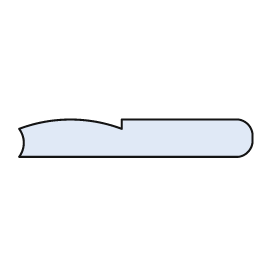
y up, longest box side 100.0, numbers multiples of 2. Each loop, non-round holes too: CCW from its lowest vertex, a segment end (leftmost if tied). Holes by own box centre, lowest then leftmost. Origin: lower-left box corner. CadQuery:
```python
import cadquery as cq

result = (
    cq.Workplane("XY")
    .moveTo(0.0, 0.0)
    .lineTo(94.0, 0.0)
    .threePointArc((98.0, 2.0), (100.0, 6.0))
    .lineTo(100.0, 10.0)
    .threePointArc((98.0, 14.0), (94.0, 16.0))
    .lineTo(44.0, 16.0)
    .lineTo(44.0, 12.0)
    .threePointArc((22.0, 16.0), (0.0, 12.0))
    .threePointArc((2.0, 6.0), (0.0, 0.0))
    .close()
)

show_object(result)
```